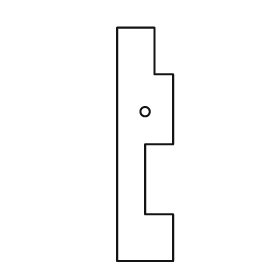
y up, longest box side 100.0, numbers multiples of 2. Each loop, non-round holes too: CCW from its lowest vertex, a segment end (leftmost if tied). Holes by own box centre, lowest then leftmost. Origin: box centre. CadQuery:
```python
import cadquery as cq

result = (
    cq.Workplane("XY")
    .moveTo(-12.0, -50.0)
    .lineTo(12.0, -50.0)
    .lineTo(12.0, -30.0)
    .lineTo(0.0, -30.0)
    .lineTo(0.0, 0.0)
    .lineTo(12.0, 0.0)
    .lineTo(12.0, 30.0)
    .lineTo(4.0, 30.0)
    .lineTo(4.0, 50.0)
    .lineTo(-12.0, 50.0)
    .close()
    .moveTo(0.0, 14.0)
    .circle(2.0)
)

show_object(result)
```